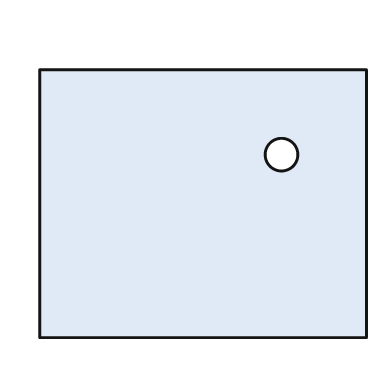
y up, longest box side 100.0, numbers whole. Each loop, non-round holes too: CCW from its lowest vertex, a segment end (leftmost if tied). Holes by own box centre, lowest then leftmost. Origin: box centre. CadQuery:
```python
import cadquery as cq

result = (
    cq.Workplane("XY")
    .moveTo(-50.0, -41.0)
    .lineTo(50.0, -41.0)
    .lineTo(50.0, 41.0)
    .lineTo(-50.0, 41.0)
    .close()
    .moveTo(24.0, 15.0)
    .circle(5.0)
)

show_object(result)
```